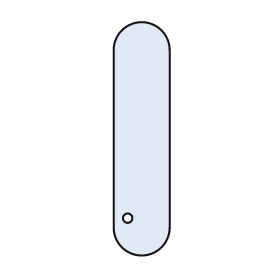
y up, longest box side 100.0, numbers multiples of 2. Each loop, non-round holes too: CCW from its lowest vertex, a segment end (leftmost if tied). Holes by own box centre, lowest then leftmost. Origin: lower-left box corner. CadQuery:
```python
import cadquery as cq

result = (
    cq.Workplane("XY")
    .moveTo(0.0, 12.0)
    .threePointArc((12.0, 0.0), (24.0, 12.0))
    .lineTo(24.0, 88.0)
    .threePointArc((12.0, 100.0), (0.0, 88.0))
    .close()
    .moveTo(6.0, 16.0)
    .circle(2.0)
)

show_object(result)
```